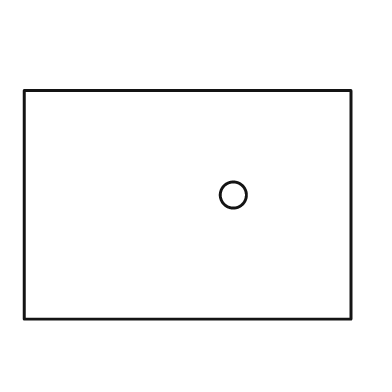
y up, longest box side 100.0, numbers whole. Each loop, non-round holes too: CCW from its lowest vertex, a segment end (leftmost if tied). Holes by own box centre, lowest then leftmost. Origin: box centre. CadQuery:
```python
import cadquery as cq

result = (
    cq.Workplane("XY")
    .moveTo(-50.0, -35.0)
    .lineTo(50.0, -35.0)
    .lineTo(50.0, 35.0)
    .lineTo(-50.0, 35.0)
    .close()
    .moveTo(14.0, 3.0)
    .circle(4.0)
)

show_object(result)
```